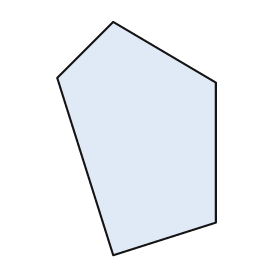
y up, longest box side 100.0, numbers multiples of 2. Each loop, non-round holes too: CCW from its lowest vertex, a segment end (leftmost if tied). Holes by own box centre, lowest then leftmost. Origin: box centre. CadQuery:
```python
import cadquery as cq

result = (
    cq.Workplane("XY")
    .moveTo(-10.0, -50.0)
    .lineTo(34.0, -36.0)
    .lineTo(34.0, 24.0)
    .lineTo(-10.0, 50.0)
    .lineTo(-34.0, 26.0)
    .close()
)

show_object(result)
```